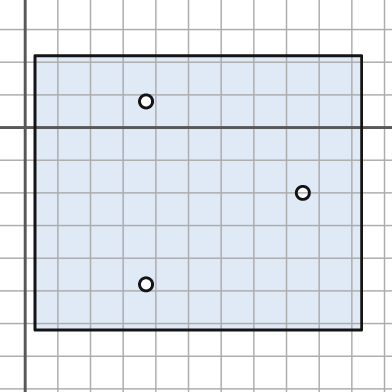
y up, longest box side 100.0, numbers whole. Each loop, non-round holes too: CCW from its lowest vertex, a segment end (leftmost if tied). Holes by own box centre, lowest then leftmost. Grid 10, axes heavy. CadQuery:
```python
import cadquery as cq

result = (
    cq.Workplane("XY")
    .moveTo(3.0, -62.0)
    .lineTo(103.0, -62.0)
    .lineTo(103.0, 22.0)
    .lineTo(3.0, 22.0)
    .close()
    .moveTo(37.0, -48.0)
    .circle(2.0)
    .moveTo(85.0, -20.0)
    .circle(2.0)
    .moveTo(37.0, 8.0)
    .circle(2.0)
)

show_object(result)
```